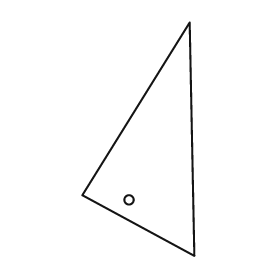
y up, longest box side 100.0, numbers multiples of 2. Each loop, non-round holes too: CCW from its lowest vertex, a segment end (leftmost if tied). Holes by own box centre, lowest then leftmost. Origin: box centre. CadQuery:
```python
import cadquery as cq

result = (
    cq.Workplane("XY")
    .moveTo(24.0, -50.0)
    .lineTo(22.0, 50.0)
    .lineTo(-24.0, -24.0)
    .close()
    .moveTo(-4.0, -26.0)
    .circle(2.0)
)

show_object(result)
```